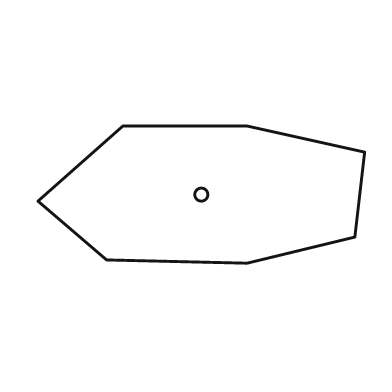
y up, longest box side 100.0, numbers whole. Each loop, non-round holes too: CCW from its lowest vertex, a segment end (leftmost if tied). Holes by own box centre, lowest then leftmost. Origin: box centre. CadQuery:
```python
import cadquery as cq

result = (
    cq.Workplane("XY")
    .moveTo(14.0, -21.0)
    .lineTo(47.0, -13.0)
    .lineTo(50.0, 13.0)
    .lineTo(14.0, 21.0)
    .lineTo(-24.0, 21.0)
    .lineTo(-50.0, -2.0)
    .lineTo(-29.0, -20.0)
    .close()
    .moveTo(0.0, 0.0)
    .circle(2.0)
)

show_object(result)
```